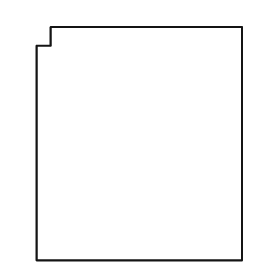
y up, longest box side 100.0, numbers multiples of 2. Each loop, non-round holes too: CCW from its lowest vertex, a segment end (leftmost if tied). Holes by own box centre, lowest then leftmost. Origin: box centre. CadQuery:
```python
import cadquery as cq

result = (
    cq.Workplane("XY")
    .moveTo(-44.0, -50.0)
    .lineTo(44.0, -50.0)
    .lineTo(44.0, 50.0)
    .lineTo(-38.0, 50.0)
    .lineTo(-38.0, 42.0)
    .lineTo(-44.0, 42.0)
    .close()
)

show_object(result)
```